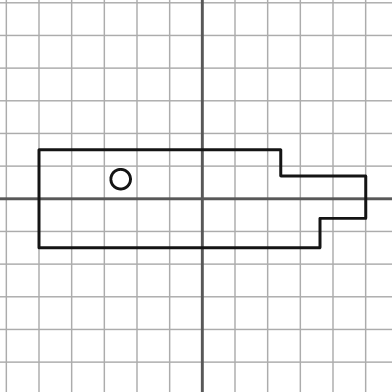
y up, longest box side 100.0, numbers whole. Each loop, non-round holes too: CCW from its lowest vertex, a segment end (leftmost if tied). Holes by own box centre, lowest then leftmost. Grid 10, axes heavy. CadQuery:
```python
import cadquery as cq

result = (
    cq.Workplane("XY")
    .moveTo(-50.0, -15.0)
    .lineTo(36.0, -15.0)
    .lineTo(36.0, -6.0)
    .lineTo(50.0, -6.0)
    .lineTo(50.0, 7.0)
    .lineTo(24.0, 7.0)
    .lineTo(24.0, 15.0)
    .lineTo(-50.0, 15.0)
    .close()
    .moveTo(-25.0, 6.0)
    .circle(3.0)
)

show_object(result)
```